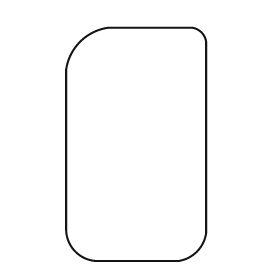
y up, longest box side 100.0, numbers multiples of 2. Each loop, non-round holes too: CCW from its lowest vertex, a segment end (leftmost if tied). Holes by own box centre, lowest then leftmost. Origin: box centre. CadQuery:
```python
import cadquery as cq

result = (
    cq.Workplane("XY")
    .moveTo(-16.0, -50.0)
    .lineTo(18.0, -50.0)
    .threePointArc((26.0, -46.0), (30.0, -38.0))
    .lineTo(30.0, 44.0)
    .threePointArc((28.0, 48.0), (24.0, 50.0))
    .lineTo(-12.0, 50.0)
    .threePointArc((-24.0, 44.0), (-30.0, 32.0))
    .lineTo(-30.0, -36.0)
    .threePointArc((-26.0, -46.0), (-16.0, -50.0))
    .close()
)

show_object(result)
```